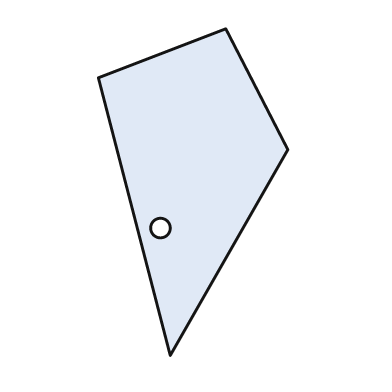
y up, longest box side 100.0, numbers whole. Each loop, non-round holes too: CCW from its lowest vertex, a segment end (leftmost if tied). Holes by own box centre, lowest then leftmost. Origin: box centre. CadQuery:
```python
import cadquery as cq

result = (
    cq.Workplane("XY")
    .moveTo(-7.0, -50.0)
    .lineTo(29.0, 13.0)
    .lineTo(10.0, 50.0)
    .lineTo(-29.0, 35.0)
    .close()
    .moveTo(-10.0, -11.0)
    .circle(3.0)
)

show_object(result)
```